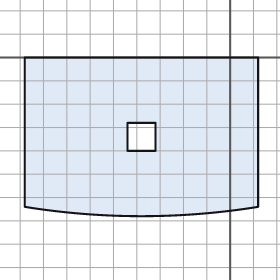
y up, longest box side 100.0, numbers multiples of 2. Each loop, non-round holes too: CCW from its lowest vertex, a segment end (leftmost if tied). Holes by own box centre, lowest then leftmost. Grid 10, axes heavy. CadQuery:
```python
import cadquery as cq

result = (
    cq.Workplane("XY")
    .moveTo(-88.0, -64.0)
    .threePointArc((-38.0, -68.0), (12.0, -64.0))
    .lineTo(12.0, 0.0)
    .lineTo(-88.0, 0.0)
    .close()
    .moveTo(-44.0, -40.0)
    .lineTo(-32.0, -40.0)
    .lineTo(-32.0, -28.0)
    .lineTo(-44.0, -28.0)
    .close()
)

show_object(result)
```